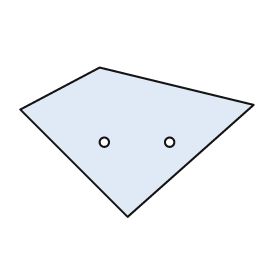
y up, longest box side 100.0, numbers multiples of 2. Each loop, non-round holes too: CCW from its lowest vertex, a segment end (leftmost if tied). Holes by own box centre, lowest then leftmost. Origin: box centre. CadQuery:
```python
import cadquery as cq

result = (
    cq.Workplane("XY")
    .moveTo(-4.0, -32.0)
    .lineTo(50.0, 16.0)
    .lineTo(-16.0, 32.0)
    .lineTo(-50.0, 14.0)
    .close()
    .moveTo(-14.0, 0.0)
    .circle(2.0)
    .moveTo(14.0, 0.0)
    .circle(2.0)
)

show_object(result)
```